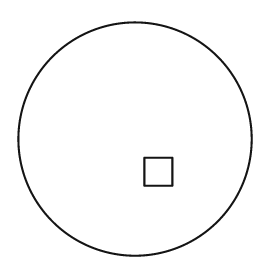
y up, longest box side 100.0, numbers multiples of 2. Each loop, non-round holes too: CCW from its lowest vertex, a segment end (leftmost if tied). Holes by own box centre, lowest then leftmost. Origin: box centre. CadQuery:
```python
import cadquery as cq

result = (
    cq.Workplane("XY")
    .moveTo(0.0, 0.0)
    .circle(50.0)
    .moveTo(4.0, -20.0)
    .lineTo(16.0, -20.0)
    .lineTo(16.0, -8.0)
    .lineTo(4.0, -8.0)
    .close()
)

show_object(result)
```